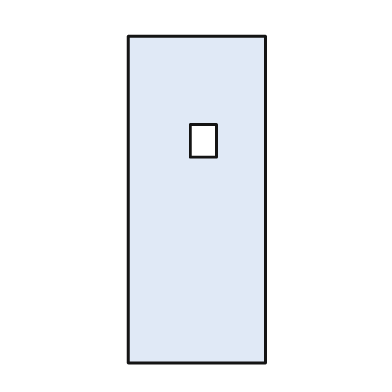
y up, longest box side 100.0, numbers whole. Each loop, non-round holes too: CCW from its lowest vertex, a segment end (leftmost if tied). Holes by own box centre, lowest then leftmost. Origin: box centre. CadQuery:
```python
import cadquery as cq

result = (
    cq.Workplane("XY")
    .moveTo(-21.0, -50.0)
    .lineTo(21.0, -50.0)
    .lineTo(21.0, 50.0)
    .lineTo(-21.0, 50.0)
    .close()
    .moveTo(-2.0, 13.0)
    .lineTo(6.0, 13.0)
    .lineTo(6.0, 23.0)
    .lineTo(-2.0, 23.0)
    .close()
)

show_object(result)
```